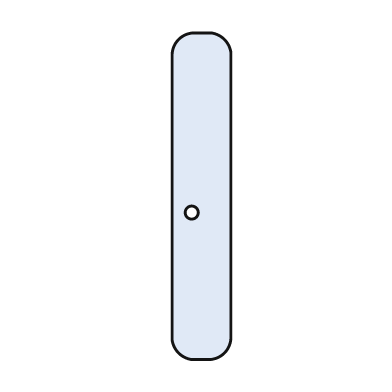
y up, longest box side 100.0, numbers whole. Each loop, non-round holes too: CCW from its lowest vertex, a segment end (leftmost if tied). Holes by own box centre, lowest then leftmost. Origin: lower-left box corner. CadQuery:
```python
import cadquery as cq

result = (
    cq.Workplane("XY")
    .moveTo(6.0, 0.0)
    .lineTo(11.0, 0.0)
    .threePointArc((16.0, 2.0), (18.0, 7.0))
    .lineTo(18.0, 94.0)
    .threePointArc((16.0, 98.0), (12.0, 100.0))
    .lineTo(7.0, 100.0)
    .threePointArc((2.0, 98.0), (0.0, 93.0))
    .lineTo(0.0, 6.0)
    .threePointArc((2.0, 2.0), (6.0, 0.0))
    .close()
    .moveTo(6.0, 45.0)
    .circle(2.0)
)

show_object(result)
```